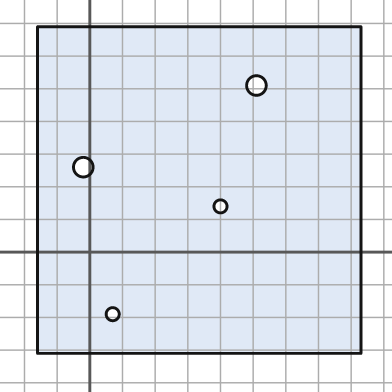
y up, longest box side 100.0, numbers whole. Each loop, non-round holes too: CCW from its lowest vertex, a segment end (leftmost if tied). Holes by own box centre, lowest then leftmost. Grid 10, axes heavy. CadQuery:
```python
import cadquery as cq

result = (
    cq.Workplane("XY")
    .moveTo(-16.0, -31.0)
    .lineTo(83.0, -31.0)
    .lineTo(83.0, 69.0)
    .lineTo(-16.0, 69.0)
    .close()
    .moveTo(7.0, -19.0)
    .circle(2.0)
    .moveTo(40.0, 14.0)
    .circle(2.0)
    .moveTo(-2.0, 26.0)
    .circle(3.0)
    .moveTo(51.0, 51.0)
    .circle(3.0)
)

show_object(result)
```